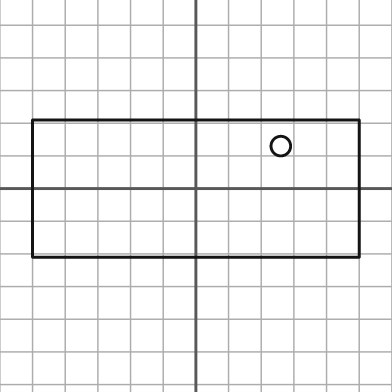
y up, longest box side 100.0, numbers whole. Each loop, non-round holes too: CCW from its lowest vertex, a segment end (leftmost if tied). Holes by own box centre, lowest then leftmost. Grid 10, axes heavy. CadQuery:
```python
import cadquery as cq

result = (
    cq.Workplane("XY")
    .moveTo(-50.0, -21.0)
    .lineTo(50.0, -21.0)
    .lineTo(50.0, 21.0)
    .lineTo(-50.0, 21.0)
    .close()
    .moveTo(26.0, 13.0)
    .circle(3.0)
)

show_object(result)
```